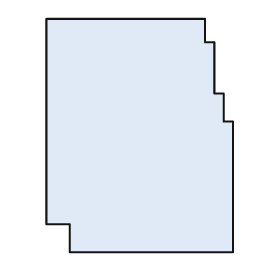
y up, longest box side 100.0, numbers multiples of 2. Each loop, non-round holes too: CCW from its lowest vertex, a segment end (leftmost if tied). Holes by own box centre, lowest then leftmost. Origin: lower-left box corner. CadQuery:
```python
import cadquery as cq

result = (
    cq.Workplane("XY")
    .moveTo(10.0, 0.0)
    .lineTo(80.0, 0.0)
    .lineTo(80.0, 56.0)
    .lineTo(76.0, 56.0)
    .lineTo(76.0, 68.0)
    .lineTo(72.0, 68.0)
    .lineTo(72.0, 90.0)
    .lineTo(68.0, 90.0)
    .lineTo(68.0, 100.0)
    .lineTo(0.0, 100.0)
    .lineTo(0.0, 12.0)
    .lineTo(10.0, 12.0)
    .close()
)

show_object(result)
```